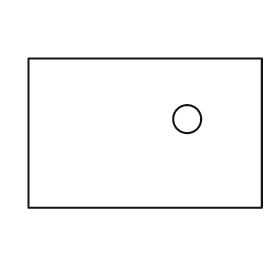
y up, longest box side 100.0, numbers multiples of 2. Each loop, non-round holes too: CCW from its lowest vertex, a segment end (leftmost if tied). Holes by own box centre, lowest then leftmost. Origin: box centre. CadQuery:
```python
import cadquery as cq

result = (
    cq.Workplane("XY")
    .moveTo(-50.0, -32.0)
    .lineTo(50.0, -32.0)
    .lineTo(50.0, 32.0)
    .lineTo(-50.0, 32.0)
    .close()
    .moveTo(18.0, 6.0)
    .circle(6.0)
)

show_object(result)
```